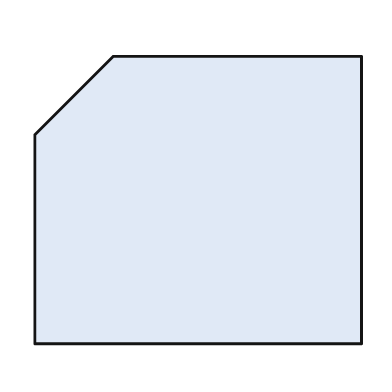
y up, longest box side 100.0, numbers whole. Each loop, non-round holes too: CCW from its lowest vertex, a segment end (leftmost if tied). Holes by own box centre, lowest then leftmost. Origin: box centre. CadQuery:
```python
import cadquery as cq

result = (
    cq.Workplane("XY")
    .moveTo(-50.0, -44.0)
    .lineTo(50.0, -44.0)
    .lineTo(50.0, 44.0)
    .lineTo(-26.0, 44.0)
    .lineTo(-50.0, 20.0)
    .close()
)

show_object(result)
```